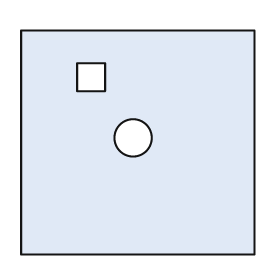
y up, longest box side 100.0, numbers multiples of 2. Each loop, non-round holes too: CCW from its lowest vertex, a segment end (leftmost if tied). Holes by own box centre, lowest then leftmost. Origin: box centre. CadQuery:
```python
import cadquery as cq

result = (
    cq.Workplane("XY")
    .moveTo(-50.0, -48.0)
    .lineTo(50.0, -48.0)
    .lineTo(50.0, 48.0)
    .lineTo(-50.0, 48.0)
    .close()
    .moveTo(-2.0, 2.0)
    .circle(8.0)
    .moveTo(-26.0, 22.0)
    .lineTo(-14.0, 22.0)
    .lineTo(-14.0, 34.0)
    .lineTo(-26.0, 34.0)
    .close()
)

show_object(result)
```